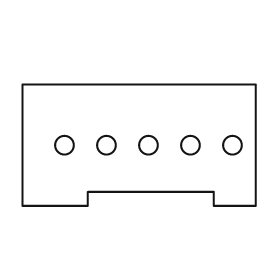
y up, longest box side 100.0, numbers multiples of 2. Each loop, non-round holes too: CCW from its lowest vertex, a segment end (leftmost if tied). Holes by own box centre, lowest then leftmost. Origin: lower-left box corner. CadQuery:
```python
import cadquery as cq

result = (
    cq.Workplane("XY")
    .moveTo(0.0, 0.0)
    .lineTo(28.0, 0.0)
    .lineTo(28.0, 6.0)
    .lineTo(82.0, 6.0)
    .lineTo(82.0, 0.0)
    .lineTo(100.0, 0.0)
    .lineTo(100.0, 52.0)
    .lineTo(0.0, 52.0)
    .close()
    .moveTo(18.0, 26.0)
    .circle(4.0)
    .moveTo(36.0, 26.0)
    .circle(4.0)
    .moveTo(54.0, 26.0)
    .circle(4.0)
    .moveTo(72.0, 26.0)
    .circle(4.0)
    .moveTo(90.0, 26.0)
    .circle(4.0)
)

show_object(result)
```